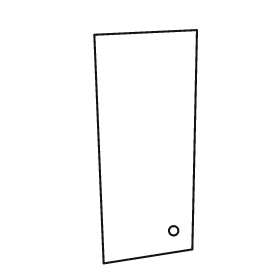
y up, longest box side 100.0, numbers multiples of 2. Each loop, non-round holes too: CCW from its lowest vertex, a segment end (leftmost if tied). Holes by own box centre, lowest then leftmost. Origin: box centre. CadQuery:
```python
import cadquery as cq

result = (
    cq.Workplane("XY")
    .moveTo(-18.0, -50.0)
    .lineTo(20.0, -44.0)
    .lineTo(22.0, 50.0)
    .lineTo(-22.0, 48.0)
    .close()
    .moveTo(12.0, -36.0)
    .circle(2.0)
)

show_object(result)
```